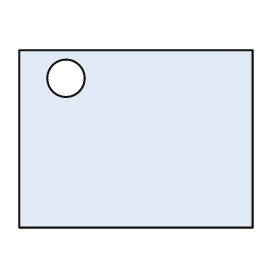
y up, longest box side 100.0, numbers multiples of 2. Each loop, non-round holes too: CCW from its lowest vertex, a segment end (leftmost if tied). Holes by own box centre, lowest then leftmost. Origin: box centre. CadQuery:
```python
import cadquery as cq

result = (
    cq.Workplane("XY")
    .moveTo(-50.0, -38.0)
    .lineTo(50.0, -38.0)
    .lineTo(50.0, 38.0)
    .lineTo(-50.0, 38.0)
    .close()
    .moveTo(-30.0, 26.0)
    .circle(8.0)
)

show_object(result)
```